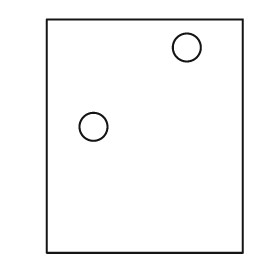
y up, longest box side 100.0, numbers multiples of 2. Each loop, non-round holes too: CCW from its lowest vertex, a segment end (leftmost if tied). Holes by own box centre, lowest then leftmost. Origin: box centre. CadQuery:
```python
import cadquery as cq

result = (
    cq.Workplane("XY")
    .moveTo(-42.0, -50.0)
    .lineTo(42.0, -50.0)
    .lineTo(42.0, 50.0)
    .lineTo(-42.0, 50.0)
    .close()
    .moveTo(-22.0, 4.0)
    .circle(6.0)
    .moveTo(18.0, 38.0)
    .circle(6.0)
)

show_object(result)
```